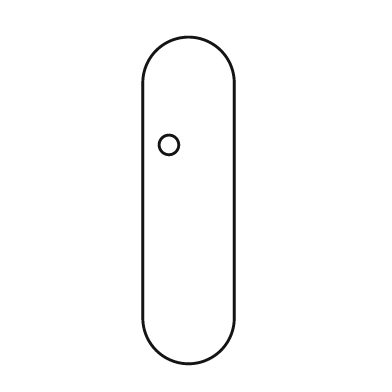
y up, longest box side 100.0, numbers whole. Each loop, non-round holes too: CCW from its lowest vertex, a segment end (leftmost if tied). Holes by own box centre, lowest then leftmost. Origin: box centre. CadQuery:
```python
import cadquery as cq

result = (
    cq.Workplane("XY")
    .moveTo(-14.0, -36.0)
    .threePointArc((0.0, -50.0), (14.0, -36.0))
    .lineTo(14.0, 36.0)
    .threePointArc((0.0, 50.0), (-14.0, 36.0))
    .close()
    .moveTo(-6.0, 17.0)
    .circle(3.0)
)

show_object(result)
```